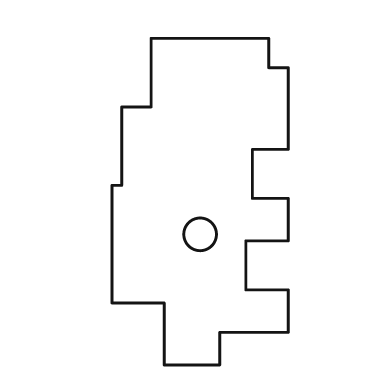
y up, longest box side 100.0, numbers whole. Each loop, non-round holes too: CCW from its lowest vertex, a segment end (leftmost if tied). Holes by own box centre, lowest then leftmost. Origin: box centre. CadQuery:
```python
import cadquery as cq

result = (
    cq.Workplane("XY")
    .moveTo(-11.0, -50.0)
    .lineTo(6.0, -50.0)
    .lineTo(6.0, -40.0)
    .lineTo(27.0, -40.0)
    .lineTo(27.0, -27.0)
    .lineTo(14.0, -27.0)
    .lineTo(14.0, -12.0)
    .lineTo(27.0, -12.0)
    .lineTo(27.0, 1.0)
    .lineTo(16.0, 1.0)
    .lineTo(16.0, 16.0)
    .lineTo(27.0, 16.0)
    .lineTo(27.0, 41.0)
    .lineTo(21.0, 41.0)
    .lineTo(21.0, 50.0)
    .lineTo(-15.0, 50.0)
    .lineTo(-15.0, 29.0)
    .lineTo(-24.0, 29.0)
    .lineTo(-24.0, 5.0)
    .lineTo(-27.0, 5.0)
    .lineTo(-27.0, -31.0)
    .lineTo(-11.0, -31.0)
    .close()
    .moveTo(0.0, -10.0)
    .circle(5.0)
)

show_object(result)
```